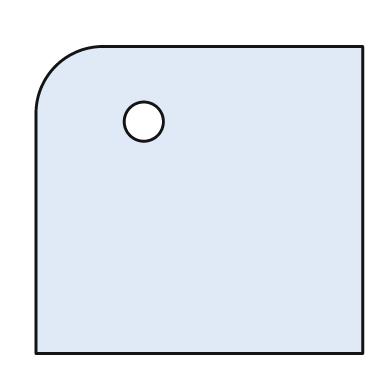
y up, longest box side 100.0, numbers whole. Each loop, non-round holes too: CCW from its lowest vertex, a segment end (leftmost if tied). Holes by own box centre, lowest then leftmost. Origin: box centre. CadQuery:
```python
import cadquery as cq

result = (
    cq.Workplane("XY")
    .moveTo(-50.0, -47.0)
    .lineTo(50.0, -47.0)
    .lineTo(50.0, 47.0)
    .lineTo(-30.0, 47.0)
    .threePointArc((-44.0, 41.0), (-50.0, 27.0))
    .close()
    .moveTo(-17.0, 24.0)
    .circle(6.0)
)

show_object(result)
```